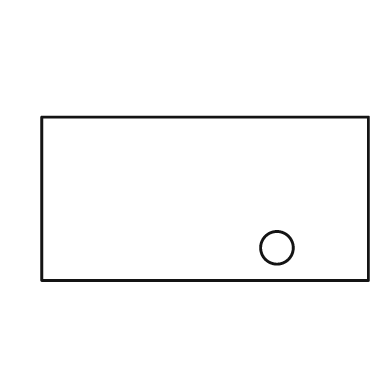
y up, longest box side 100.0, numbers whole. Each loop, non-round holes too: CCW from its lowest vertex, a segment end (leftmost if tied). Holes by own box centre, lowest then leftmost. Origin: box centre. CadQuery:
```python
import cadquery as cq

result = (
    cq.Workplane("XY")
    .moveTo(-50.0, -25.0)
    .lineTo(50.0, -25.0)
    .lineTo(50.0, 25.0)
    .lineTo(-50.0, 25.0)
    .close()
    .moveTo(22.0, -15.0)
    .circle(5.0)
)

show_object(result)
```